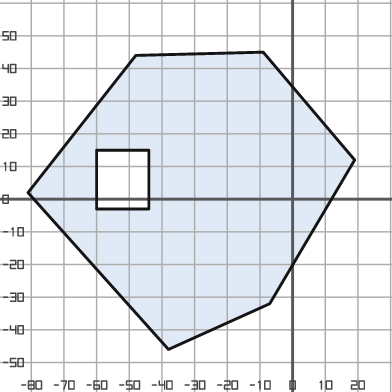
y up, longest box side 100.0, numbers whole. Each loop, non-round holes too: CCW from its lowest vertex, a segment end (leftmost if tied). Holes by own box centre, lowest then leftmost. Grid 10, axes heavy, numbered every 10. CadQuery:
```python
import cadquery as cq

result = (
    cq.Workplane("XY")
    .moveTo(-38.0, -46.0)
    .lineTo(-7.0, -32.0)
    .lineTo(19.0, 12.0)
    .lineTo(-9.0, 45.0)
    .lineTo(-48.0, 44.0)
    .lineTo(-81.0, 2.0)
    .close()
    .moveTo(-60.0, -3.0)
    .lineTo(-44.0, -3.0)
    .lineTo(-44.0, 15.0)
    .lineTo(-60.0, 15.0)
    .close()
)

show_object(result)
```